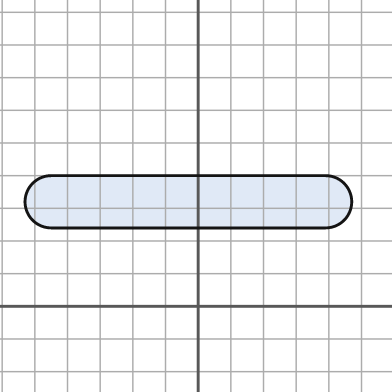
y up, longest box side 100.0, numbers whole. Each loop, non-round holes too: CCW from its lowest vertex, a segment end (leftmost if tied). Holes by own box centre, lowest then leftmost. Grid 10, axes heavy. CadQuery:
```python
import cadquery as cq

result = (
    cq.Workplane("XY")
    .moveTo(-45.0, 24.0)
    .lineTo(39.0, 24.0)
    .threePointArc((47.0, 32.0), (39.0, 40.0))
    .lineTo(-45.0, 40.0)
    .threePointArc((-53.0, 32.0), (-45.0, 24.0))
    .close()
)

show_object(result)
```